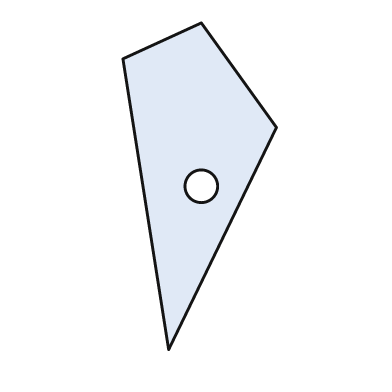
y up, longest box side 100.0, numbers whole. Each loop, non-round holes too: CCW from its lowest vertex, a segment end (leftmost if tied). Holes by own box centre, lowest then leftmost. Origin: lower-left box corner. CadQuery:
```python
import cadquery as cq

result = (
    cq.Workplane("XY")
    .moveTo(14.0, 0.0)
    .lineTo(47.0, 68.0)
    .lineTo(24.0, 100.0)
    .lineTo(0.0, 89.0)
    .close()
    .moveTo(24.0, 50.0)
    .circle(5.0)
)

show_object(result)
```